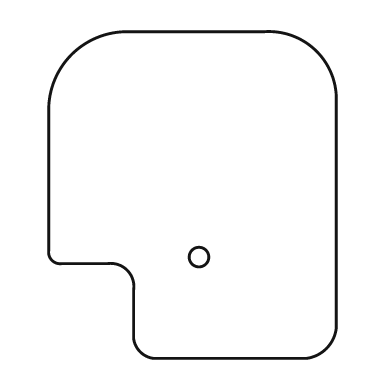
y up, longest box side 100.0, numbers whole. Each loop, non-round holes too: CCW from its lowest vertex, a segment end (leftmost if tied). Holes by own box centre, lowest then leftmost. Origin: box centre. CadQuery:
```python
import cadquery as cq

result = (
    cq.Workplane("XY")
    .moveTo(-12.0, -50.0)
    .lineTo(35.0, -50.0)
    .threePointArc((41.0, -47.0), (44.0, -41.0))
    .lineTo(44.0, 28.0)
    .threePointArc((38.0, 44.0), (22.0, 50.0))
    .lineTo(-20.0, 50.0)
    .threePointArc((-37.0, 43.0), (-44.0, 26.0))
    .lineTo(-44.0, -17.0)
    .threePointArc((-43.0, -20.0), (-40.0, -21.0))
    .lineTo(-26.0, -21.0)
    .threePointArc((-20.0, -23.0), (-18.0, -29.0))
    .lineTo(-18.0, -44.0)
    .threePointArc((-16.0, -48.0), (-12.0, -50.0))
    .close()
    .moveTo(2.0, -19.0)
    .circle(3.0)
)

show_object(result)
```